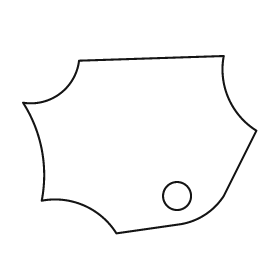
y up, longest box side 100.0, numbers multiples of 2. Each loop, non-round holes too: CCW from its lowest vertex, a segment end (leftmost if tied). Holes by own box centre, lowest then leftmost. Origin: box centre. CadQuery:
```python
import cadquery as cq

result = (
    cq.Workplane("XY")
    .moveTo(-10.0, -38.0)
    .lineTo(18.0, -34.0)
    .threePointArc((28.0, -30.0), (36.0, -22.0))
    .lineTo(50.0, 6.0)
    .threePointArc((38.0, 20.0), (36.0, 38.0))
    .lineTo(-26.0, 36.0)
    .threePointArc((-34.0, 22.0), (-50.0, 18.0))
    .threePointArc((-42.0, -2.0), (-42.0, -24.0))
    .threePointArc((-24.0, -26.0), (-10.0, -38.0))
    .close()
    .moveTo(16.0, -22.0)
    .circle(6.0)
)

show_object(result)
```